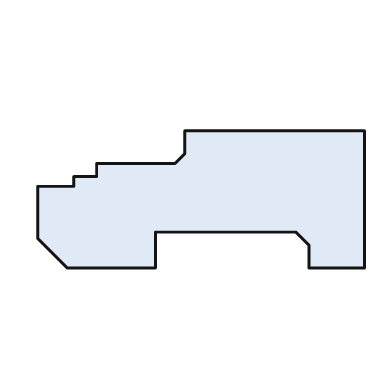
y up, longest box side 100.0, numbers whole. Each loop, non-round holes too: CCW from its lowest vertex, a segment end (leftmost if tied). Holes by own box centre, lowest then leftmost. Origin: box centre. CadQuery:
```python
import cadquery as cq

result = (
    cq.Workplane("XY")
    .moveTo(-41.0, -21.0)
    .lineTo(-14.0, -21.0)
    .lineTo(-14.0, -10.0)
    .lineTo(29.0, -10.0)
    .lineTo(33.0, -14.0)
    .lineTo(33.0, -21.0)
    .lineTo(50.0, -21.0)
    .lineTo(50.0, 21.0)
    .lineTo(-5.0, 21.0)
    .lineTo(-5.0, 14.0)
    .lineTo(-8.0, 11.0)
    .lineTo(-32.0, 11.0)
    .lineTo(-32.0, 7.0)
    .lineTo(-39.0, 7.0)
    .lineTo(-39.0, 4.0)
    .lineTo(-50.0, 4.0)
    .lineTo(-50.0, -12.0)
    .close()
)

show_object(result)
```